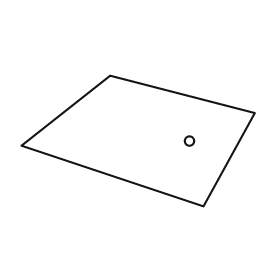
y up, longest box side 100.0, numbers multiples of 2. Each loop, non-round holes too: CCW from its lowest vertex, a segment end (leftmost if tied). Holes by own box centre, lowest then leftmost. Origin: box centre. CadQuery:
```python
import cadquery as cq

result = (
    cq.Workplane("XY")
    .moveTo(28.0, -28.0)
    .lineTo(50.0, 12.0)
    .lineTo(-12.0, 28.0)
    .lineTo(-50.0, -2.0)
    .close()
    .moveTo(22.0, 0.0)
    .circle(2.0)
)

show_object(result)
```